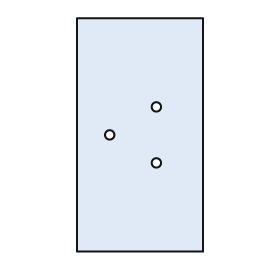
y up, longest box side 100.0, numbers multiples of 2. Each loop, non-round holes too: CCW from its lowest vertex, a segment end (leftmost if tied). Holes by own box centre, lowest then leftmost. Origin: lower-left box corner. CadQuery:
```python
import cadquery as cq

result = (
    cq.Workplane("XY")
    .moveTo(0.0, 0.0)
    .lineTo(54.0, 0.0)
    .lineTo(54.0, 100.0)
    .lineTo(0.0, 100.0)
    .close()
    .moveTo(34.0, 38.0)
    .circle(2.0)
    .moveTo(14.0, 50.0)
    .circle(2.0)
    .moveTo(34.0, 62.0)
    .circle(2.0)
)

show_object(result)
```